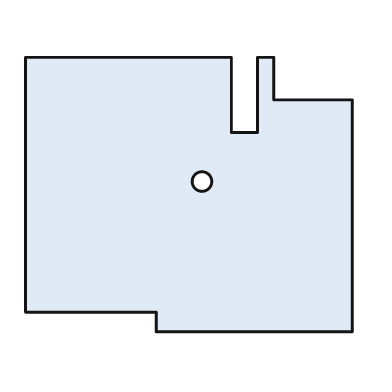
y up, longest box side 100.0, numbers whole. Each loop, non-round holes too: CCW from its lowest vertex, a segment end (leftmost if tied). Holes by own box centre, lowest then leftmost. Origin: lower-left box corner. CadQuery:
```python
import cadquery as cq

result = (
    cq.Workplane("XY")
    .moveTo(40.0, 0.0)
    .lineTo(100.0, 0.0)
    .lineTo(100.0, 71.0)
    .lineTo(76.0, 71.0)
    .lineTo(76.0, 84.0)
    .lineTo(71.0, 84.0)
    .lineTo(71.0, 61.0)
    .lineTo(63.0, 61.0)
    .lineTo(63.0, 84.0)
    .lineTo(0.0, 84.0)
    .lineTo(0.0, 6.0)
    .lineTo(40.0, 6.0)
    .close()
    .moveTo(54.0, 46.0)
    .circle(3.0)
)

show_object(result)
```